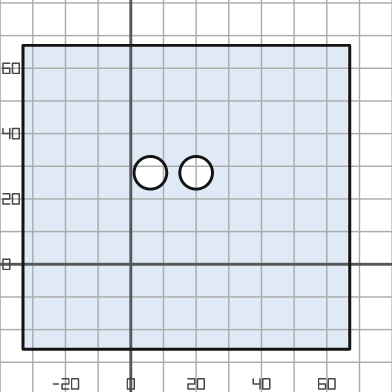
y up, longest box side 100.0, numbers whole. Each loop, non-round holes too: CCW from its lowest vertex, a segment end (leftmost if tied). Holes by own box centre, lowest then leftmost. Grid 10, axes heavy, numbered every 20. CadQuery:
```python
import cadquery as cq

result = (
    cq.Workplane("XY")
    .moveTo(-33.0, -26.0)
    .lineTo(67.0, -26.0)
    .lineTo(67.0, 67.0)
    .lineTo(-33.0, 67.0)
    .close()
    .moveTo(6.0, 28.0)
    .circle(5.0)
    .moveTo(20.0, 28.0)
    .circle(5.0)
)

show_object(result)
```